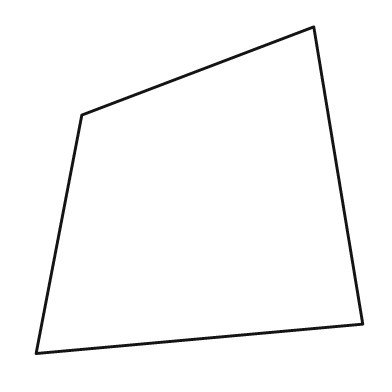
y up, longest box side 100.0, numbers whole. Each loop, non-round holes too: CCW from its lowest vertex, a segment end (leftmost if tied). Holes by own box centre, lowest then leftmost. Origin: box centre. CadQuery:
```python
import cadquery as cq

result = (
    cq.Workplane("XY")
    .moveTo(-50.0, -50.0)
    .lineTo(50.0, -41.0)
    .lineTo(35.0, 50.0)
    .lineTo(-36.0, 23.0)
    .close()
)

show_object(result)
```